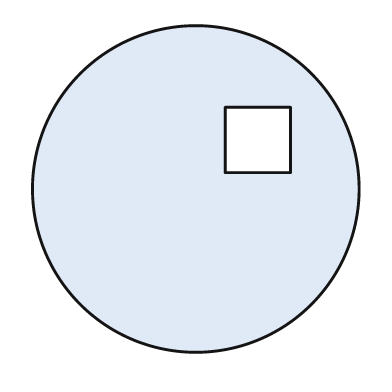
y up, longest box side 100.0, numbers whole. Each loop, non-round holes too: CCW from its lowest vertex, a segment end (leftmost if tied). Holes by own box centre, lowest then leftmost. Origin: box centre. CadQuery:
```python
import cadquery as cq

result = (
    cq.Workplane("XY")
    .moveTo(0.0, 0.0)
    .circle(50.0)
    .moveTo(9.0, 5.0)
    .lineTo(29.0, 5.0)
    .lineTo(29.0, 25.0)
    .lineTo(9.0, 25.0)
    .close()
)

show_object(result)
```